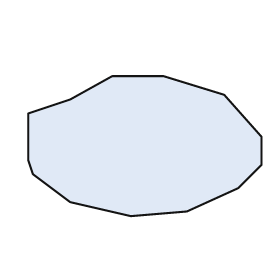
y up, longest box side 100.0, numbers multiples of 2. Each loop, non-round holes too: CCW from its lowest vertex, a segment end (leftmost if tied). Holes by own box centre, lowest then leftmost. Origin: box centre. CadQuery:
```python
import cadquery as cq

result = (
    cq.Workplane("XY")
    .moveTo(-6.0, -30.0)
    .lineTo(18.0, -28.0)
    .lineTo(40.0, -18.0)
    .lineTo(50.0, -8.0)
    .lineTo(50.0, 4.0)
    .lineTo(34.0, 22.0)
    .lineTo(8.0, 30.0)
    .lineTo(-14.0, 30.0)
    .lineTo(-32.0, 20.0)
    .lineTo(-50.0, 14.0)
    .lineTo(-50.0, -6.0)
    .lineTo(-48.0, -12.0)
    .lineTo(-32.0, -24.0)
    .close()
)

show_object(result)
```